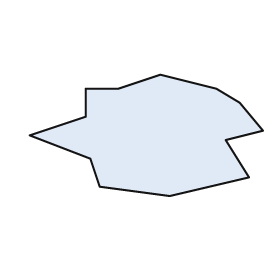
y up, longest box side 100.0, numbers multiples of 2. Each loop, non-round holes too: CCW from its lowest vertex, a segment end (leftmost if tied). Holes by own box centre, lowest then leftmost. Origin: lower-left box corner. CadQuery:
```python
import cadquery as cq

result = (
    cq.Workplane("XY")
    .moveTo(60.0, 0.0)
    .lineTo(94.0, 8.0)
    .lineTo(84.0, 24.0)
    .lineTo(100.0, 28.0)
    .lineTo(90.0, 40.0)
    .lineTo(80.0, 46.0)
    .lineTo(56.0, 52.0)
    .lineTo(38.0, 46.0)
    .lineTo(24.0, 46.0)
    .lineTo(24.0, 34.0)
    .lineTo(0.0, 26.0)
    .lineTo(26.0, 16.0)
    .lineTo(30.0, 4.0)
    .close()
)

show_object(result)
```